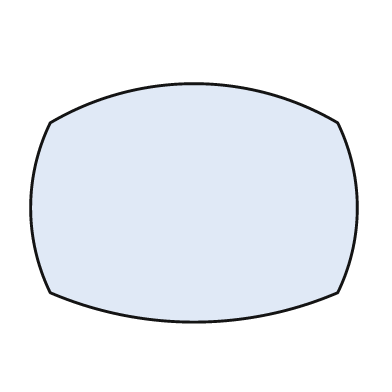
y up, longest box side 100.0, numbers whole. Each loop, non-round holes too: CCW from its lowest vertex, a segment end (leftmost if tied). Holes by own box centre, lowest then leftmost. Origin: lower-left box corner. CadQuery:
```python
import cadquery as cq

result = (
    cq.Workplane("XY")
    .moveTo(6.0, 9.0)
    .threePointArc((50.0, 0.0), (94.0, 9.0))
    .threePointArc((100.0, 35.0), (94.0, 61.0))
    .threePointArc((50.0, 73.0), (6.0, 61.0))
    .threePointArc((0.0, 35.0), (6.0, 9.0))
    .close()
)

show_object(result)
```